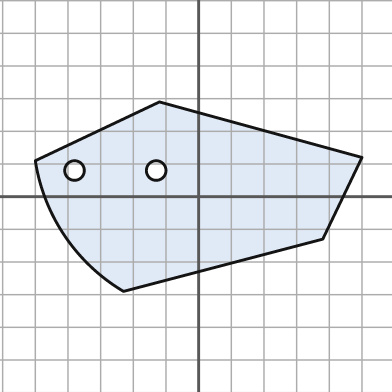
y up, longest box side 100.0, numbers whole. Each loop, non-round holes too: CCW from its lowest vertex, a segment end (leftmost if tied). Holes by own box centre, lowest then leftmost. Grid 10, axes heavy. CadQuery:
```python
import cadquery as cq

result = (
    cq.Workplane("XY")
    .moveTo(-23.0, -29.0)
    .lineTo(38.0, -13.0)
    .lineTo(50.0, 12.0)
    .lineTo(-12.0, 29.0)
    .lineTo(-50.0, 11.0)
    .threePointArc((-41.0, -12.0), (-23.0, -29.0))
    .close()
    .moveTo(-38.0, 8.0)
    .circle(3.0)
    .moveTo(-13.0, 8.0)
    .circle(3.0)
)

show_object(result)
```